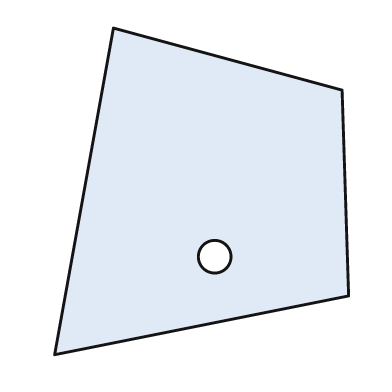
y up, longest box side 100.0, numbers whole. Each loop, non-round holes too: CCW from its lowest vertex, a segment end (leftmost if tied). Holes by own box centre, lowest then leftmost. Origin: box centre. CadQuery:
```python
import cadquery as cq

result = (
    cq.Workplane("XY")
    .moveTo(-45.0, -50.0)
    .lineTo(45.0, -32.0)
    .lineTo(43.0, 31.0)
    .lineTo(-27.0, 50.0)
    .close()
    .moveTo(4.0, -20.0)
    .circle(5.0)
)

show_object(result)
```